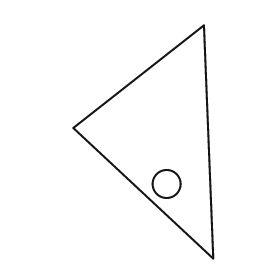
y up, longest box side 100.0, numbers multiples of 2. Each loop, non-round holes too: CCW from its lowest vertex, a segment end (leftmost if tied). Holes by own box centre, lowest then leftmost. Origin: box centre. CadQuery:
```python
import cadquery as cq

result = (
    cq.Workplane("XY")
    .moveTo(30.0, -50.0)
    .lineTo(26.0, 50.0)
    .lineTo(-30.0, 6.0)
    .close()
    .moveTo(10.0, -18.0)
    .circle(6.0)
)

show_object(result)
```